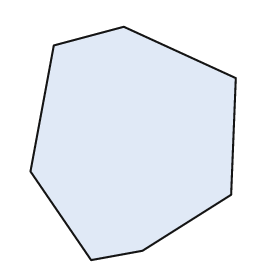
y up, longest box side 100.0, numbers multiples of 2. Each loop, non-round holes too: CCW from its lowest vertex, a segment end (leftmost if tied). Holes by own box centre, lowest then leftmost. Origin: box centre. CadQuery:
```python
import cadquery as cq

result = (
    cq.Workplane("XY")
    .moveTo(-18.0, -50.0)
    .lineTo(4.0, -46.0)
    .lineTo(42.0, -22.0)
    .lineTo(44.0, 28.0)
    .lineTo(-4.0, 50.0)
    .lineTo(-34.0, 42.0)
    .lineTo(-44.0, -12.0)
    .close()
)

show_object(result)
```